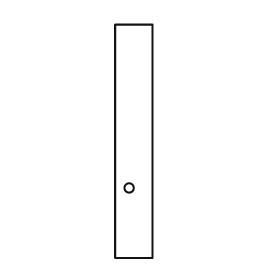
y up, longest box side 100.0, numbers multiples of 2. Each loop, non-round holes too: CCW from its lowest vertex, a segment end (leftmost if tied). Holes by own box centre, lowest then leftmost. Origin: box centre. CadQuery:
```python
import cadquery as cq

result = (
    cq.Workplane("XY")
    .moveTo(-8.0, -50.0)
    .lineTo(8.0, -50.0)
    .lineTo(8.0, 50.0)
    .lineTo(-8.0, 50.0)
    .close()
    .moveTo(-2.0, -20.0)
    .circle(2.0)
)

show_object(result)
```